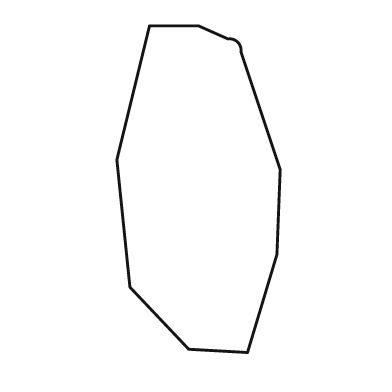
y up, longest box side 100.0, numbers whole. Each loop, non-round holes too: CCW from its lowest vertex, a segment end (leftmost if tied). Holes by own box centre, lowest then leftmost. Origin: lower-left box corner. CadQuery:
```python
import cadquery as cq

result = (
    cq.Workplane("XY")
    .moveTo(40.0, 0.0)
    .lineTo(49.0, 30.0)
    .lineTo(50.0, 56.0)
    .lineTo(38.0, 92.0)
    .threePointArc((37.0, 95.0), (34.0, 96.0))
    .lineTo(25.0, 100.0)
    .lineTo(10.0, 100.0)
    .lineTo(0.0, 59.0)
    .lineTo(4.0, 20.0)
    .lineTo(22.0, 1.0)
    .close()
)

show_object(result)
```